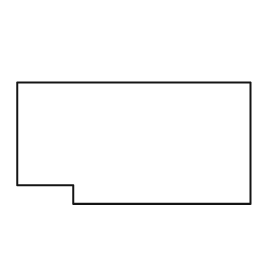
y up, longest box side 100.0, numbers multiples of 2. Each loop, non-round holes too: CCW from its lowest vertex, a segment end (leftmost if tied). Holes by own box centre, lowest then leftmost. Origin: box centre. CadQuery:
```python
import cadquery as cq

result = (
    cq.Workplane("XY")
    .moveTo(-26.0, -26.0)
    .lineTo(50.0, -26.0)
    .lineTo(50.0, 26.0)
    .lineTo(-50.0, 26.0)
    .lineTo(-50.0, -18.0)
    .lineTo(-26.0, -18.0)
    .close()
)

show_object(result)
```